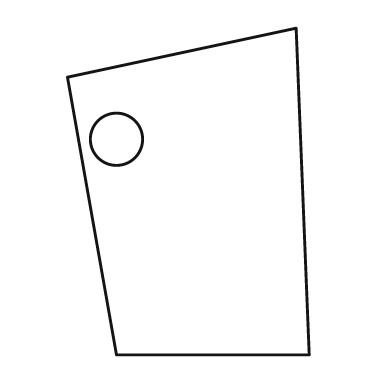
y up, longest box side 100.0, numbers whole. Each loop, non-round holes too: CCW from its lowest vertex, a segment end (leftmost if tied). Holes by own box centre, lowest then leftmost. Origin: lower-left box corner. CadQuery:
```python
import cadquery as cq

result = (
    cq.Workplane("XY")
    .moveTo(15.0, 0.0)
    .lineTo(74.0, 0.0)
    .lineTo(70.0, 100.0)
    .lineTo(0.0, 85.0)
    .close()
    .moveTo(15.0, 66.0)
    .circle(8.0)
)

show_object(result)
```